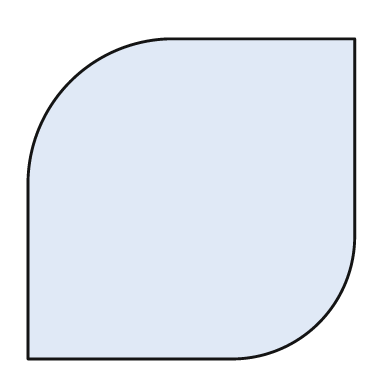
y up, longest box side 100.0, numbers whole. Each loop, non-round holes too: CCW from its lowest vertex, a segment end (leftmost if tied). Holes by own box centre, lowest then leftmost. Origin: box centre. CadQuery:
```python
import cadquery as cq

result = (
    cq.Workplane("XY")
    .moveTo(-50.0, -49.0)
    .lineTo(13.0, -49.0)
    .threePointArc((39.0, -38.0), (50.0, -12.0))
    .lineTo(50.0, 49.0)
    .lineTo(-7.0, 49.0)
    .threePointArc((-37.0, 36.0), (-50.0, 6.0))
    .close()
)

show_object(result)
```